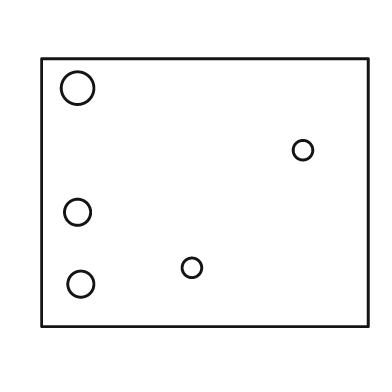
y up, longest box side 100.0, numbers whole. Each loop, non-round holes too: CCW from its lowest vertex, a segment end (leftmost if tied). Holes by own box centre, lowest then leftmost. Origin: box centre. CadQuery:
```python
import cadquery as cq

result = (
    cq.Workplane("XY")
    .moveTo(-50.0, -41.0)
    .lineTo(50.0, -41.0)
    .lineTo(50.0, 41.0)
    .lineTo(-50.0, 41.0)
    .close()
    .moveTo(-38.0, -28.0)
    .circle(4.0)
    .moveTo(-4.0, -23.0)
    .circle(3.0)
    .moveTo(-39.0, -6.0)
    .circle(4.0)
    .moveTo(30.0, 13.0)
    .circle(3.0)
    .moveTo(-39.0, 32.0)
    .circle(5.0)
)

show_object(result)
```